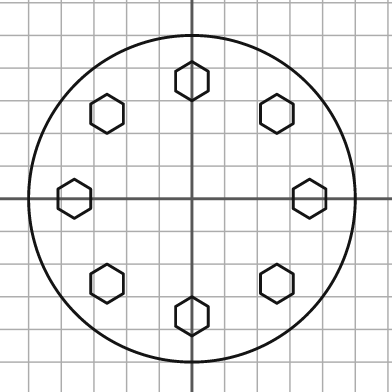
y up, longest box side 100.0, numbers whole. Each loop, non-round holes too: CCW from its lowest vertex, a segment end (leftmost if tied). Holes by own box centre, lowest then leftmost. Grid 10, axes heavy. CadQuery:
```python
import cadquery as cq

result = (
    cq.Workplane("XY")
    .moveTo(0.0, 0.0)
    .circle(50.0)
    .moveTo(0.0, -42.0)
    .lineTo(5.0, -39.0)
    .lineTo(5.0, -33.0)
    .lineTo(0.0, -30.0)
    .lineTo(-5.0, -33.0)
    .lineTo(-5.0, -39.0)
    .close()
    .moveTo(-26.0, -32.0)
    .lineTo(-21.0, -29.0)
    .lineTo(-21.0, -23.0)
    .lineTo(-26.0, -20.0)
    .lineTo(-31.0, -23.0)
    .lineTo(-31.0, -29.0)
    .close()
    .moveTo(26.0, -32.0)
    .lineTo(31.0, -29.0)
    .lineTo(31.0, -23.0)
    .lineTo(26.0, -20.0)
    .lineTo(21.0, -23.0)
    .lineTo(21.0, -29.0)
    .close()
    .moveTo(-36.0, -6.0)
    .lineTo(-31.0, -3.0)
    .lineTo(-31.0, 3.0)
    .lineTo(-36.0, 6.0)
    .lineTo(-41.0, 3.0)
    .lineTo(-41.0, -3.0)
    .close()
    .moveTo(36.0, -6.0)
    .lineTo(41.0, -3.0)
    .lineTo(41.0, 3.0)
    .lineTo(36.0, 6.0)
    .lineTo(31.0, 3.0)
    .lineTo(31.0, -3.0)
    .close()
    .moveTo(-26.0, 20.0)
    .lineTo(-21.0, 23.0)
    .lineTo(-21.0, 29.0)
    .lineTo(-26.0, 32.0)
    .lineTo(-31.0, 29.0)
    .lineTo(-31.0, 23.0)
    .close()
    .moveTo(26.0, 20.0)
    .lineTo(31.0, 23.0)
    .lineTo(31.0, 29.0)
    .lineTo(26.0, 32.0)
    .lineTo(21.0, 29.0)
    .lineTo(21.0, 23.0)
    .close()
    .moveTo(0.0, 30.0)
    .lineTo(5.0, 33.0)
    .lineTo(5.0, 39.0)
    .lineTo(0.0, 42.0)
    .lineTo(-5.0, 39.0)
    .lineTo(-5.0, 33.0)
    .close()
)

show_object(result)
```